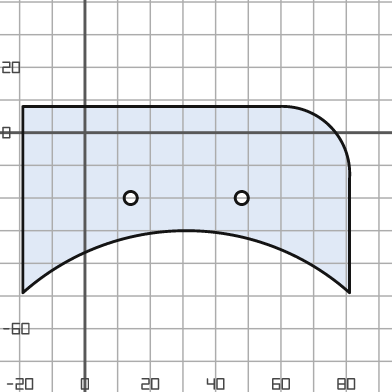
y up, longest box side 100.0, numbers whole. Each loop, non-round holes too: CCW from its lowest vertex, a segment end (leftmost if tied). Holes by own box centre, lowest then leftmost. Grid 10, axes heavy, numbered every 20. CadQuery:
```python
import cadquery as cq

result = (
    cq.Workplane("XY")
    .moveTo(-19.0, -49.0)
    .threePointArc((31.0, -30.0), (81.0, -49.0))
    .lineTo(81.0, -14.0)
    .threePointArc((75.0, 2.0), (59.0, 8.0))
    .lineTo(-19.0, 8.0)
    .close()
    .moveTo(14.0, -20.0)
    .circle(2.0)
    .moveTo(48.0, -20.0)
    .circle(2.0)
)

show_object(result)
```